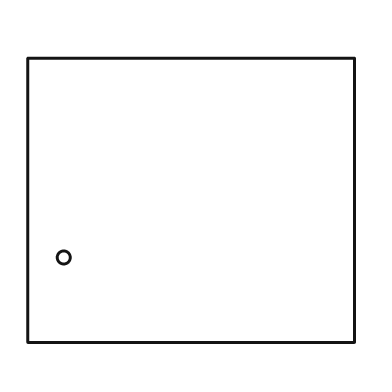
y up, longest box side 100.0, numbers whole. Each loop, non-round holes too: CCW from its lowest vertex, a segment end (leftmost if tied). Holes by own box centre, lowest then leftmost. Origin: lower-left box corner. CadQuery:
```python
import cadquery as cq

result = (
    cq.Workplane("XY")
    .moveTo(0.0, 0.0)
    .lineTo(100.0, 0.0)
    .lineTo(100.0, 87.0)
    .lineTo(0.0, 87.0)
    .close()
    .moveTo(11.0, 26.0)
    .circle(2.0)
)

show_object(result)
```